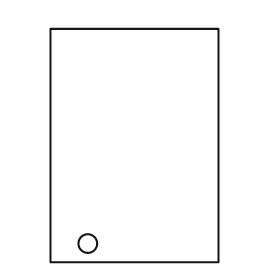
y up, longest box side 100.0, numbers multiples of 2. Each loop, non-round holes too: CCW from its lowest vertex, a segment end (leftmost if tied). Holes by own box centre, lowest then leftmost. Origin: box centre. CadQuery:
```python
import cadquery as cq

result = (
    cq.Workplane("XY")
    .moveTo(-36.0, -50.0)
    .lineTo(36.0, -50.0)
    .lineTo(36.0, 50.0)
    .lineTo(-36.0, 50.0)
    .close()
    .moveTo(-20.0, -42.0)
    .circle(4.0)
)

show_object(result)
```